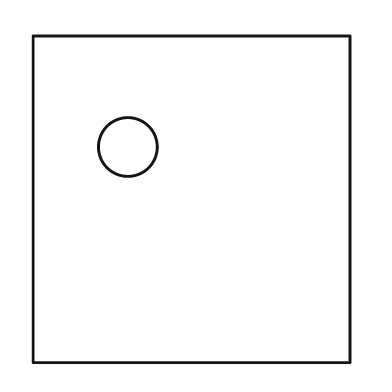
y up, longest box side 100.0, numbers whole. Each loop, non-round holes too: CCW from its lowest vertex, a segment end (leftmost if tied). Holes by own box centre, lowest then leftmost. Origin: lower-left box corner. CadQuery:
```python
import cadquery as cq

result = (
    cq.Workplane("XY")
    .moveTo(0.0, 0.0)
    .lineTo(97.0, 0.0)
    .lineTo(97.0, 100.0)
    .lineTo(0.0, 100.0)
    .close()
    .moveTo(29.0, 66.0)
    .circle(9.0)
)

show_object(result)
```